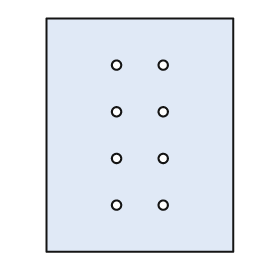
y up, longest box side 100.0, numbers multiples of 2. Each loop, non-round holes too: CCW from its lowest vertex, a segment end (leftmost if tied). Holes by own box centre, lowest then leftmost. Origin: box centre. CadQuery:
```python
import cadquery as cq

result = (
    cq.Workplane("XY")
    .moveTo(-40.0, -50.0)
    .lineTo(40.0, -50.0)
    .lineTo(40.0, 50.0)
    .lineTo(-40.0, 50.0)
    .close()
    .moveTo(-10.0, -30.0)
    .circle(2.0)
    .moveTo(10.0, -30.0)
    .circle(2.0)
    .moveTo(-10.0, -10.0)
    .circle(2.0)
    .moveTo(10.0, -10.0)
    .circle(2.0)
    .moveTo(-10.0, 10.0)
    .circle(2.0)
    .moveTo(10.0, 10.0)
    .circle(2.0)
    .moveTo(-10.0, 30.0)
    .circle(2.0)
    .moveTo(10.0, 30.0)
    .circle(2.0)
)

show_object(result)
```